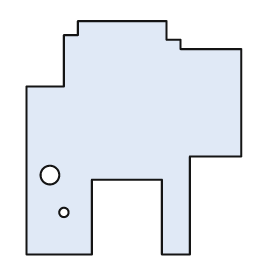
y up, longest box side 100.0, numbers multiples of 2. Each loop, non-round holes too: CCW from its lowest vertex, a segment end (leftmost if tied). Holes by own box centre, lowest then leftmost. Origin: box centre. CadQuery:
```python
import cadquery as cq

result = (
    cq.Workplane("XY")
    .moveTo(-46.0, -50.0)
    .lineTo(-18.0, -50.0)
    .lineTo(-18.0, -18.0)
    .lineTo(12.0, -18.0)
    .lineTo(12.0, -50.0)
    .lineTo(24.0, -50.0)
    .lineTo(24.0, -8.0)
    .lineTo(46.0, -8.0)
    .lineTo(46.0, 38.0)
    .lineTo(20.0, 38.0)
    .lineTo(20.0, 42.0)
    .lineTo(14.0, 42.0)
    .lineTo(14.0, 50.0)
    .lineTo(-24.0, 50.0)
    .lineTo(-24.0, 44.0)
    .lineTo(-30.0, 44.0)
    .lineTo(-30.0, 22.0)
    .lineTo(-46.0, 22.0)
    .close()
    .moveTo(-30.0, -32.0)
    .circle(2.0)
    .moveTo(-36.0, -16.0)
    .circle(4.0)
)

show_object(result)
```